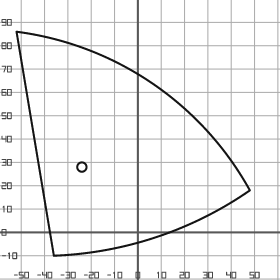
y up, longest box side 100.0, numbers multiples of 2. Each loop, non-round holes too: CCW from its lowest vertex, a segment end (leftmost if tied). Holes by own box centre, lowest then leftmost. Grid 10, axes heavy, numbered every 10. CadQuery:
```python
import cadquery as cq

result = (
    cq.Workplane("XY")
    .moveTo(-36.0, -10.0)
    .threePointArc((8.0, -2.0), (48.0, 18.0))
    .threePointArc((6.0, 64.0), (-52.0, 86.0))
    .close()
    .moveTo(-24.0, 28.0)
    .circle(2.0)
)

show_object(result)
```